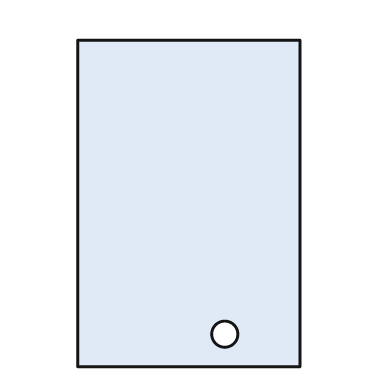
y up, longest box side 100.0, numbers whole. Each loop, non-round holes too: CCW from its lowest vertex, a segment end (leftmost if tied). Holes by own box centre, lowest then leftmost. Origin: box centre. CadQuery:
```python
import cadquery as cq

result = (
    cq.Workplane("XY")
    .moveTo(-34.0, -50.0)
    .lineTo(34.0, -50.0)
    .lineTo(34.0, 50.0)
    .lineTo(-34.0, 50.0)
    .close()
    .moveTo(11.0, -40.0)
    .circle(4.0)
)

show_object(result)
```